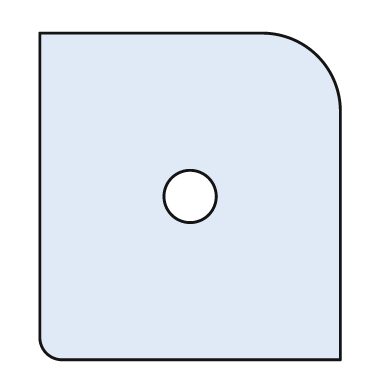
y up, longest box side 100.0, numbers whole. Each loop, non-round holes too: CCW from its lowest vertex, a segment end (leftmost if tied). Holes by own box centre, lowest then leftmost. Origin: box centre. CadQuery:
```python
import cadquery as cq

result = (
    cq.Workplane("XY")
    .moveTo(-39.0, -50.0)
    .lineTo(46.0, -50.0)
    .lineTo(46.0, 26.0)
    .threePointArc((39.0, 43.0), (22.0, 50.0))
    .lineTo(-46.0, 50.0)
    .lineTo(-46.0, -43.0)
    .threePointArc((-44.0, -48.0), (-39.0, -50.0))
    .close()
    .moveTo(0.0, 0.0)
    .circle(8.0)
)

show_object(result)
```